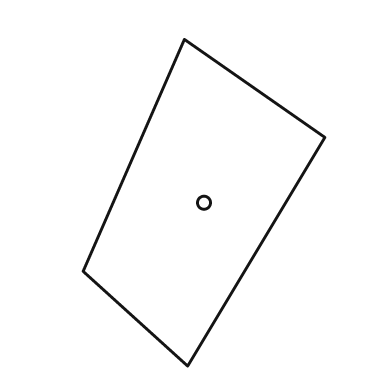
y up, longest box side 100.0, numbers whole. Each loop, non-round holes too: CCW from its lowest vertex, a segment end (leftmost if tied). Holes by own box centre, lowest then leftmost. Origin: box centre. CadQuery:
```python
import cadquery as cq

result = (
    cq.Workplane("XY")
    .moveTo(-5.0, -50.0)
    .lineTo(37.0, 20.0)
    .lineTo(-6.0, 50.0)
    .lineTo(-37.0, -21.0)
    .close()
    .moveTo(0.0, 0.0)
    .circle(2.0)
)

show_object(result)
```